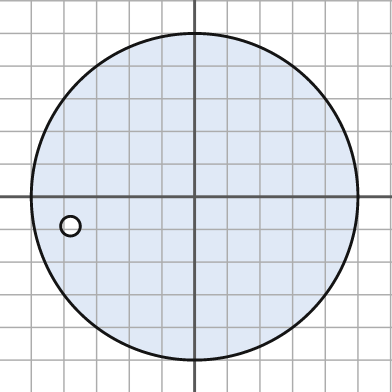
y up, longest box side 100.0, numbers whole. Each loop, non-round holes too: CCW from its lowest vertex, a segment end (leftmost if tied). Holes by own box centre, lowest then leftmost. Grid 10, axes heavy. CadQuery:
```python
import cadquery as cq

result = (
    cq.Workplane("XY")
    .moveTo(0.0, 0.0)
    .circle(50.0)
    .moveTo(-38.0, -9.0)
    .circle(3.0)
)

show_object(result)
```